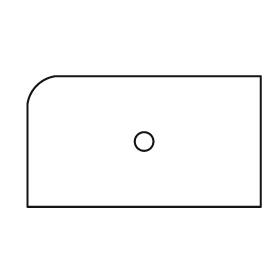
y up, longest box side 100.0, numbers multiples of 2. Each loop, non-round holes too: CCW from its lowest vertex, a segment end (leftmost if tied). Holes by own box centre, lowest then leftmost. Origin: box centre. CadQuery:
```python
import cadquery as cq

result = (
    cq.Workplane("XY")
    .moveTo(-50.0, -28.0)
    .lineTo(50.0, -28.0)
    .lineTo(50.0, 28.0)
    .lineTo(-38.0, 28.0)
    .threePointArc((-46.0, 24.0), (-50.0, 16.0))
    .close()
    .moveTo(0.0, 0.0)
    .circle(4.0)
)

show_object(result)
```